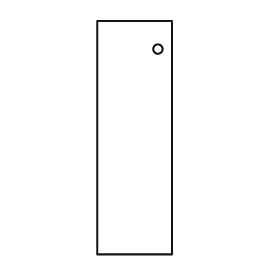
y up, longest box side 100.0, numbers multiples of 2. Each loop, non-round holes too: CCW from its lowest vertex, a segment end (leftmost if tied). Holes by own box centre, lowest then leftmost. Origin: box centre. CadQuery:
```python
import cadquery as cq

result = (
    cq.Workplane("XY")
    .moveTo(-16.0, -50.0)
    .lineTo(16.0, -50.0)
    .lineTo(16.0, 50.0)
    .lineTo(-16.0, 50.0)
    .close()
    .moveTo(10.0, 38.0)
    .circle(2.0)
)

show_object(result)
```